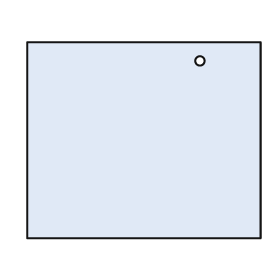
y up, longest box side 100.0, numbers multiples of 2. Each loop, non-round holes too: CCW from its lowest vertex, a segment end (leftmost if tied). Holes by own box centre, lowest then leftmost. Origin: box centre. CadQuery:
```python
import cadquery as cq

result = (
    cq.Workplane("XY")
    .moveTo(-50.0, -42.0)
    .lineTo(50.0, -42.0)
    .lineTo(50.0, 42.0)
    .lineTo(-50.0, 42.0)
    .close()
    .moveTo(24.0, 34.0)
    .circle(2.0)
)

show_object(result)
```